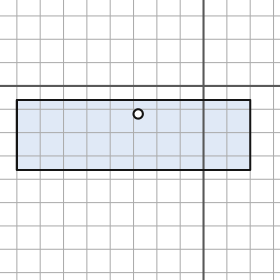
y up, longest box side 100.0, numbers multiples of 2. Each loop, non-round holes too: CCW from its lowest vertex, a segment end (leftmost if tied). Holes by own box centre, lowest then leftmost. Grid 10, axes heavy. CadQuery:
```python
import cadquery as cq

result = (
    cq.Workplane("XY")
    .moveTo(-80.0, -36.0)
    .lineTo(20.0, -36.0)
    .lineTo(20.0, -6.0)
    .lineTo(-80.0, -6.0)
    .close()
    .moveTo(-28.0, -12.0)
    .circle(2.0)
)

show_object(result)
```